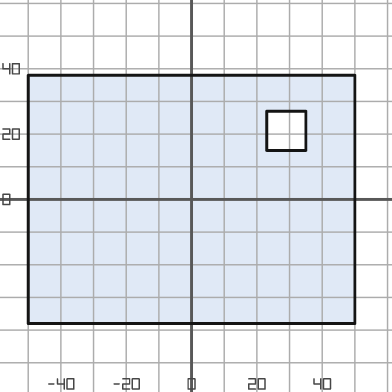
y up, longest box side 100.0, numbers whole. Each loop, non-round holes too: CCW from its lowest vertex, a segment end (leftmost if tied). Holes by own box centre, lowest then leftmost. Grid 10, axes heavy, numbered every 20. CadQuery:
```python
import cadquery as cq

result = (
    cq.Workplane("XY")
    .moveTo(-50.0, -38.0)
    .lineTo(50.0, -38.0)
    .lineTo(50.0, 38.0)
    .lineTo(-50.0, 38.0)
    .close()
    .moveTo(23.0, 15.0)
    .lineTo(35.0, 15.0)
    .lineTo(35.0, 27.0)
    .lineTo(23.0, 27.0)
    .close()
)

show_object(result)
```